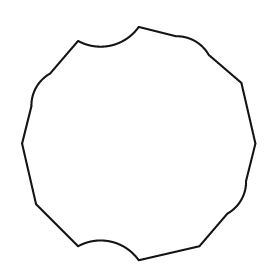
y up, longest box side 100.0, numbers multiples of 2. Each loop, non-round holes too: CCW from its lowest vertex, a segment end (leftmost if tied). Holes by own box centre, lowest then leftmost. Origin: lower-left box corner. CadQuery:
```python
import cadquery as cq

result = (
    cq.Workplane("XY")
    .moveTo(50.0, 0.0)
    .lineTo(76.0, 6.0)
    .lineTo(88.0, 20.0)
    .threePointArc((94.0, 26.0), (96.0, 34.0))
    .lineTo(100.0, 50.0)
    .lineTo(94.0, 76.0)
    .lineTo(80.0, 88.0)
    .threePointArc((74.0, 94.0), (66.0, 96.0))
    .lineTo(50.0, 100.0)
    .threePointArc((38.0, 92.0), (24.0, 94.0))
    .lineTo(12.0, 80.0)
    .threePointArc((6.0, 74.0), (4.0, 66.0))
    .lineTo(0.0, 50.0)
    .lineTo(6.0, 24.0)
    .lineTo(24.0, 6.0)
    .threePointArc((38.0, 8.0), (50.0, 0.0))
    .close()
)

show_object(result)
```